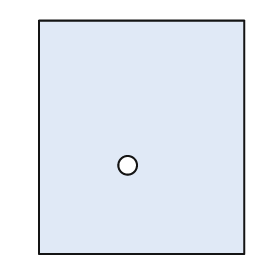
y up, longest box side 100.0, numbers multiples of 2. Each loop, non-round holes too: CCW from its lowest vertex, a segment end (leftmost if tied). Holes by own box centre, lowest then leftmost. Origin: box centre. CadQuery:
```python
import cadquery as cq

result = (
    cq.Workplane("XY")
    .moveTo(-44.0, -50.0)
    .lineTo(44.0, -50.0)
    .lineTo(44.0, 50.0)
    .lineTo(-44.0, 50.0)
    .close()
    .moveTo(-6.0, -12.0)
    .circle(4.0)
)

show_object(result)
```